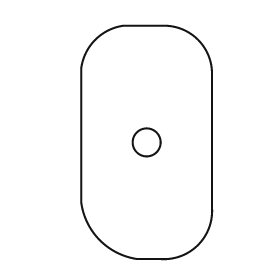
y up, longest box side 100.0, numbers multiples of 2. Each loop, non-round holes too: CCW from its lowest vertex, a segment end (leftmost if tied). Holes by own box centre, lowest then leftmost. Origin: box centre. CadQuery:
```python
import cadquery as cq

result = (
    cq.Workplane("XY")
    .moveTo(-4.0, -50.0)
    .lineTo(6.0, -50.0)
    .threePointArc((22.0, -44.0), (28.0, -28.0))
    .lineTo(28.0, 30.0)
    .threePointArc((22.0, 44.0), (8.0, 50.0))
    .lineTo(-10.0, 50.0)
    .threePointArc((-22.0, 44.0), (-28.0, 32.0))
    .lineTo(-28.0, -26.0)
    .threePointArc((-20.0, -42.0), (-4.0, -50.0))
    .close()
    .moveTo(0.0, 0.0)
    .circle(6.0)
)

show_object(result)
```